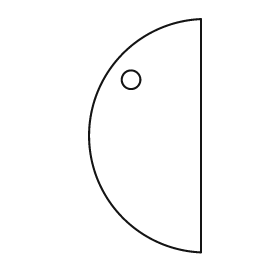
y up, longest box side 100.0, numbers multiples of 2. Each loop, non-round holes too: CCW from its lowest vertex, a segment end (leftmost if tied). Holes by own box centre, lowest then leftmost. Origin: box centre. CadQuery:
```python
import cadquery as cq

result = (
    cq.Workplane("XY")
    .moveTo(24.0, -50.0)
    .lineTo(24.0, 50.0)
    .threePointArc((-24.0, 0.0), (24.0, -50.0))
    .close()
    .moveTo(-6.0, 24.0)
    .circle(4.0)
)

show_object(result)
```